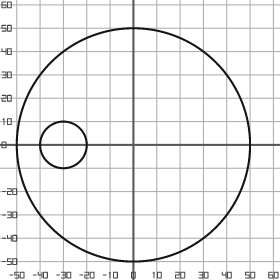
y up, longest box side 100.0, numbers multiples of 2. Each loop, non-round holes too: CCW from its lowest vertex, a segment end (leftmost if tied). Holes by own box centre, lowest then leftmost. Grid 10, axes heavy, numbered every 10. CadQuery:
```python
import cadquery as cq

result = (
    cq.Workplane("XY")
    .moveTo(0.0, 0.0)
    .circle(50.0)
    .moveTo(-30.0, 0.0)
    .circle(10.0)
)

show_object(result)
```